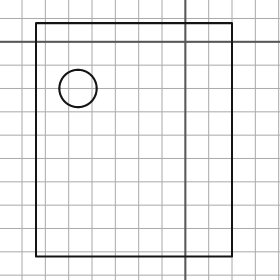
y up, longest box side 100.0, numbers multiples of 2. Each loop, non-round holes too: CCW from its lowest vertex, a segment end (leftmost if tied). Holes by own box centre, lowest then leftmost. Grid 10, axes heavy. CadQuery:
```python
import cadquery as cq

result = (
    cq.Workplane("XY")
    .moveTo(-64.0, -92.0)
    .lineTo(20.0, -92.0)
    .lineTo(20.0, 8.0)
    .lineTo(-64.0, 8.0)
    .close()
    .moveTo(-46.0, -20.0)
    .circle(8.0)
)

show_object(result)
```